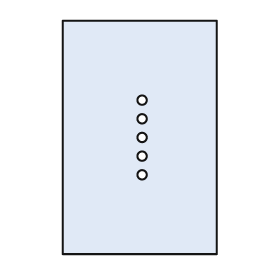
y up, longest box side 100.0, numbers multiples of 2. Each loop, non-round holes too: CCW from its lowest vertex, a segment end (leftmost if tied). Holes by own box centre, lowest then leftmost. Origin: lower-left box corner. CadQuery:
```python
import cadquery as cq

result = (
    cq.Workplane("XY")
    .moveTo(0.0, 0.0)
    .lineTo(66.0, 0.0)
    .lineTo(66.0, 100.0)
    .lineTo(0.0, 100.0)
    .close()
    .moveTo(34.0, 34.0)
    .circle(2.0)
    .moveTo(34.0, 42.0)
    .circle(2.0)
    .moveTo(34.0, 50.0)
    .circle(2.0)
    .moveTo(34.0, 58.0)
    .circle(2.0)
    .moveTo(34.0, 66.0)
    .circle(2.0)
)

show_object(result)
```